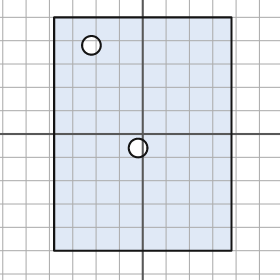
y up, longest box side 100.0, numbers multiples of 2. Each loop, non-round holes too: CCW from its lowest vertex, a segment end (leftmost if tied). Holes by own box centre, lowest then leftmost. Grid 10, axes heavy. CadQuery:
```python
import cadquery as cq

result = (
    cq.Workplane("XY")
    .moveTo(-38.0, -50.0)
    .lineTo(38.0, -50.0)
    .lineTo(38.0, 50.0)
    .lineTo(-38.0, 50.0)
    .close()
    .moveTo(-2.0, -6.0)
    .circle(4.0)
    .moveTo(-22.0, 38.0)
    .circle(4.0)
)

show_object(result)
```